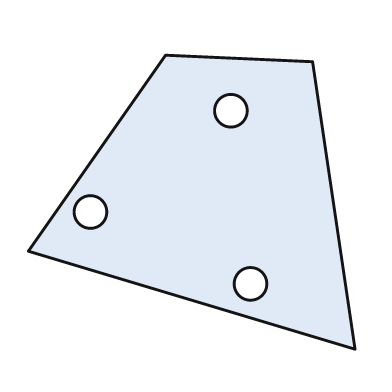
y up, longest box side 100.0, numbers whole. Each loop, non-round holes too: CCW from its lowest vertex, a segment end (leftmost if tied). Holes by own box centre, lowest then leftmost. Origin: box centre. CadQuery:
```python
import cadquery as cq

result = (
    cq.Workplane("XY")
    .moveTo(50.0, -45.0)
    .lineTo(37.0, 43.0)
    .lineTo(-8.0, 45.0)
    .lineTo(-50.0, -15.0)
    .close()
    .moveTo(18.0, -25.0)
    .circle(5.0)
    .moveTo(-31.0, -3.0)
    .circle(5.0)
    .moveTo(12.0, 28.0)
    .circle(5.0)
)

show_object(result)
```